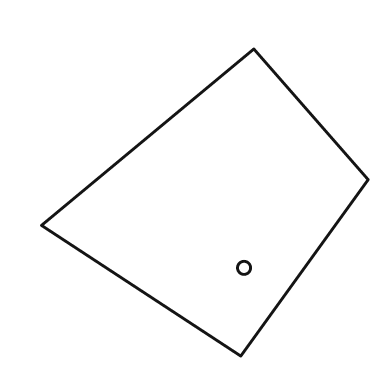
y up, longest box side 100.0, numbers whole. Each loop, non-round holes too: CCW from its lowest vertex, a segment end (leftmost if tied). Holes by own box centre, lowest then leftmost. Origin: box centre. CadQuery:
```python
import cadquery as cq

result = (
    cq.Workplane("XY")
    .moveTo(11.0, -47.0)
    .lineTo(50.0, 7.0)
    .lineTo(15.0, 47.0)
    .lineTo(-50.0, -7.0)
    .close()
    .moveTo(12.0, -20.0)
    .circle(2.0)
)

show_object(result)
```